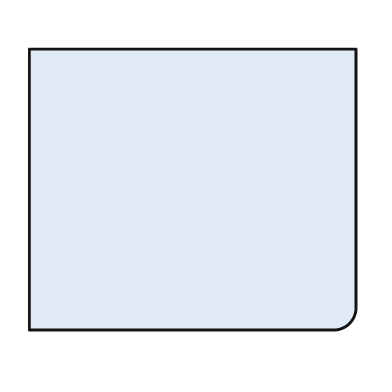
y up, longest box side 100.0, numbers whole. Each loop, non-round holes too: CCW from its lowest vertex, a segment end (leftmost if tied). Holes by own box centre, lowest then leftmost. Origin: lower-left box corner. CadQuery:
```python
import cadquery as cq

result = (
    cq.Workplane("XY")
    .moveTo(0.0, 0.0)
    .lineTo(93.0, 0.0)
    .threePointArc((98.0, 2.0), (100.0, 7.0))
    .lineTo(100.0, 86.0)
    .lineTo(0.0, 86.0)
    .close()
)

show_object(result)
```